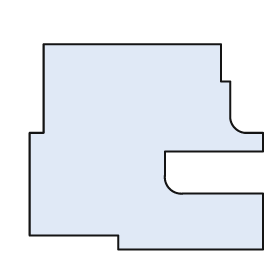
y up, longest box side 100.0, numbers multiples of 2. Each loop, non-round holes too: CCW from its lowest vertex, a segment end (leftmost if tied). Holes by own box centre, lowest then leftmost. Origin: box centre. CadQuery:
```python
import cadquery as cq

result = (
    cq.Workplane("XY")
    .moveTo(-12.0, -44.0)
    .lineTo(50.0, -44.0)
    .lineTo(50.0, -20.0)
    .lineTo(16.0, -20.0)
    .threePointArc((10.0, -18.0), (8.0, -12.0))
    .lineTo(8.0, -2.0)
    .lineTo(50.0, -2.0)
    .lineTo(50.0, 6.0)
    .lineTo(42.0, 6.0)
    .threePointArc((38.0, 8.0), (36.0, 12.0))
    .lineTo(36.0, 28.0)
    .lineTo(32.0, 28.0)
    .lineTo(32.0, 44.0)
    .lineTo(-44.0, 44.0)
    .lineTo(-44.0, 6.0)
    .lineTo(-50.0, 6.0)
    .lineTo(-50.0, -38.0)
    .lineTo(-12.0, -38.0)
    .close()
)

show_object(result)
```